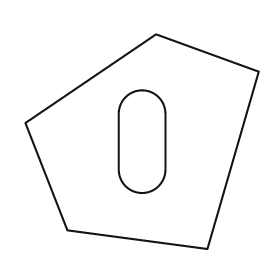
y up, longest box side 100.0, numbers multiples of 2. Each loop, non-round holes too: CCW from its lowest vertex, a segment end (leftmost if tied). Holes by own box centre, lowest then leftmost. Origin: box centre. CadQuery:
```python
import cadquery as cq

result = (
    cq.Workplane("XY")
    .moveTo(28.0, -46.0)
    .lineTo(50.0, 30.0)
    .lineTo(6.0, 46.0)
    .lineTo(-50.0, 8.0)
    .lineTo(-32.0, -38.0)
    .close()
    .moveTo(-10.0, -12.0)
    .threePointArc((0.0, -22.0), (10.0, -12.0))
    .lineTo(10.0, 12.0)
    .threePointArc((0.0, 22.0), (-10.0, 12.0))
    .close()
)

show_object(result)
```